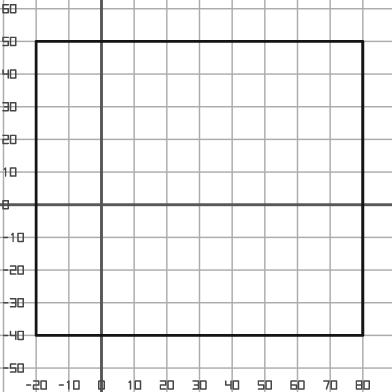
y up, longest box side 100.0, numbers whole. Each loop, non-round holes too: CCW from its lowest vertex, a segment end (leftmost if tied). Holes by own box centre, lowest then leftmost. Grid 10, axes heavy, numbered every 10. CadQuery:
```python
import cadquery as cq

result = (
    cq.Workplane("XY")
    .moveTo(-20.0, -40.0)
    .lineTo(80.0, -40.0)
    .lineTo(80.0, 50.0)
    .lineTo(-20.0, 50.0)
    .close()
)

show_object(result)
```